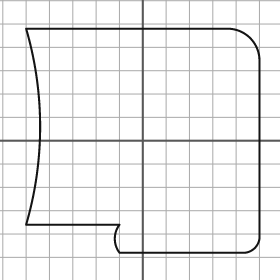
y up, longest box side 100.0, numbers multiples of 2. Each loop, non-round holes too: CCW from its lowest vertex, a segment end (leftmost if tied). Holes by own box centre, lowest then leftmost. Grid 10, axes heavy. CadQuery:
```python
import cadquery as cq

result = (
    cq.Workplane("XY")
    .moveTo(-10.0, -48.0)
    .lineTo(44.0, -48.0)
    .threePointArc((48.0, -46.0), (50.0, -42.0))
    .lineTo(50.0, 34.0)
    .threePointArc((46.0, 44.0), (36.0, 48.0))
    .lineTo(-50.0, 48.0)
    .threePointArc((-44.0, 6.0), (-50.0, -36.0))
    .lineTo(-10.0, -36.0)
    .threePointArc((-12.0, -42.0), (-10.0, -48.0))
    .close()
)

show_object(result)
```